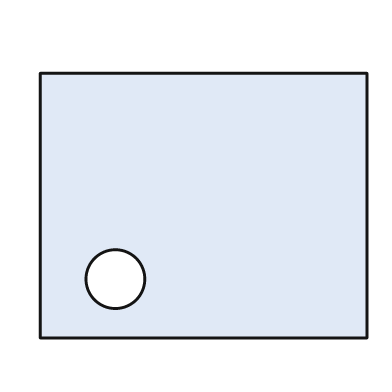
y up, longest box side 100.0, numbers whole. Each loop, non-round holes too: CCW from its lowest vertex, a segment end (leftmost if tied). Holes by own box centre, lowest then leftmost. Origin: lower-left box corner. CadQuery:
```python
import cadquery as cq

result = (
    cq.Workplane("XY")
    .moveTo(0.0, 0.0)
    .lineTo(100.0, 0.0)
    .lineTo(100.0, 81.0)
    .lineTo(0.0, 81.0)
    .close()
    .moveTo(23.0, 18.0)
    .circle(9.0)
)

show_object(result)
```